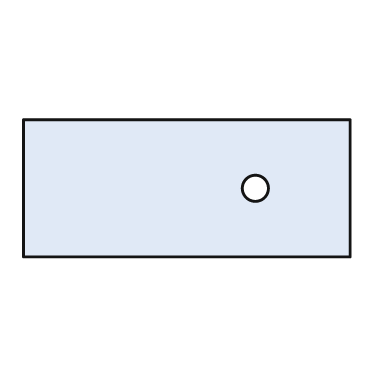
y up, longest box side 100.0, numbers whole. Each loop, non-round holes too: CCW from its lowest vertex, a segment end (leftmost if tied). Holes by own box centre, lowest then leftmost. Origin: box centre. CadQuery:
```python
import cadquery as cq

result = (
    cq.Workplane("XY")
    .moveTo(-50.0, -21.0)
    .lineTo(50.0, -21.0)
    .lineTo(50.0, 21.0)
    .lineTo(-50.0, 21.0)
    .close()
    .moveTo(21.0, 0.0)
    .circle(4.0)
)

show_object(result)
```